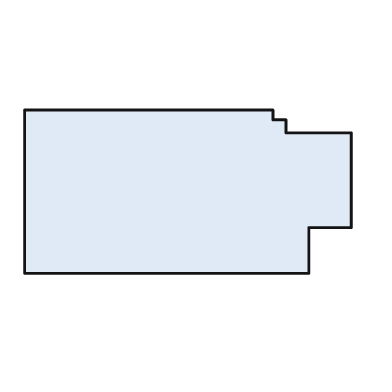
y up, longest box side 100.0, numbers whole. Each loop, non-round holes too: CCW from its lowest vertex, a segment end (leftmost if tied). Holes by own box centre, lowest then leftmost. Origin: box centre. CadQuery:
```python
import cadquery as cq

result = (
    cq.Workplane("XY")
    .moveTo(-50.0, -25.0)
    .lineTo(37.0, -25.0)
    .lineTo(37.0, -11.0)
    .lineTo(50.0, -11.0)
    .lineTo(50.0, 18.0)
    .lineTo(30.0, 18.0)
    .lineTo(30.0, 22.0)
    .lineTo(26.0, 22.0)
    .lineTo(26.0, 25.0)
    .lineTo(-50.0, 25.0)
    .close()
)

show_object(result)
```